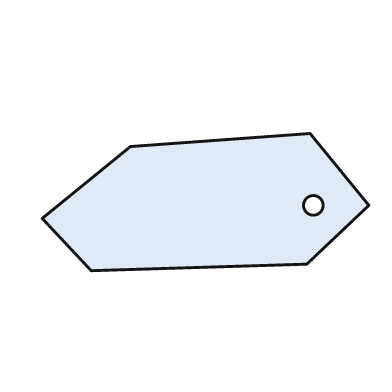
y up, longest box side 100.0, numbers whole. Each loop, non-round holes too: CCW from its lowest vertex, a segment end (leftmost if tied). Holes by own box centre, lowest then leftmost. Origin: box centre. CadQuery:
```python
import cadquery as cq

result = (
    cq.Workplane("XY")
    .moveTo(-35.0, -21.0)
    .lineTo(31.0, -19.0)
    .lineTo(50.0, -1.0)
    .lineTo(32.0, 21.0)
    .lineTo(-23.0, 17.0)
    .lineTo(-50.0, -5.0)
    .close()
    .moveTo(33.0, -1.0)
    .circle(3.0)
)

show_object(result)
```